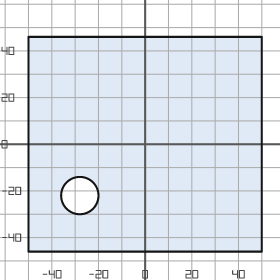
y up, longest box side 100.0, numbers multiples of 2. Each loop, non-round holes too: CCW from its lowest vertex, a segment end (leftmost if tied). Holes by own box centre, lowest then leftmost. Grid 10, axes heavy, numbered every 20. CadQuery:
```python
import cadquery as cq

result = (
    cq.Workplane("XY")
    .moveTo(-50.0, -46.0)
    .lineTo(50.0, -46.0)
    .lineTo(50.0, 46.0)
    .lineTo(-50.0, 46.0)
    .close()
    .moveTo(-28.0, -22.0)
    .circle(8.0)
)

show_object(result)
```